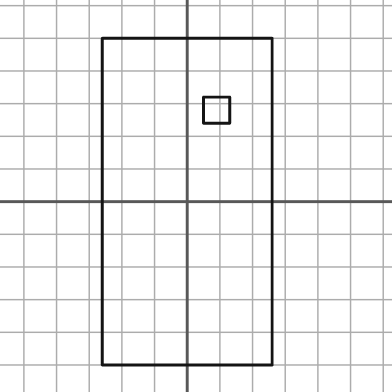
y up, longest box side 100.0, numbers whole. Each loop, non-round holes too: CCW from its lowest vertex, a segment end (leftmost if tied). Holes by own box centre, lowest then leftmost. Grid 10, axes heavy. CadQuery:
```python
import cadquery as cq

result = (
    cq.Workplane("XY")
    .moveTo(-26.0, -50.0)
    .lineTo(26.0, -50.0)
    .lineTo(26.0, 50.0)
    .lineTo(-26.0, 50.0)
    .close()
    .moveTo(5.0, 24.0)
    .lineTo(13.0, 24.0)
    .lineTo(13.0, 32.0)
    .lineTo(5.0, 32.0)
    .close()
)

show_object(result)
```